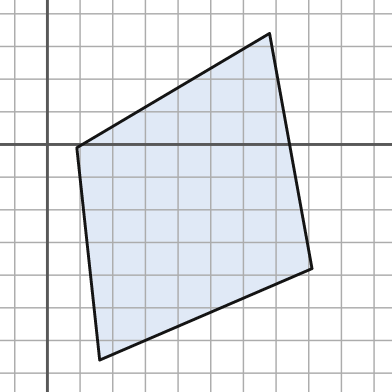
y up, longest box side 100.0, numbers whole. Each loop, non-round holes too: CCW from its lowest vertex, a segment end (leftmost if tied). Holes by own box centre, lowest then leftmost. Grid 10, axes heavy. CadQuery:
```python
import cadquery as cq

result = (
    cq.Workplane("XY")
    .moveTo(16.0, -66.0)
    .lineTo(81.0, -38.0)
    .lineTo(68.0, 34.0)
    .lineTo(9.0, -1.0)
    .close()
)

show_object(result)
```